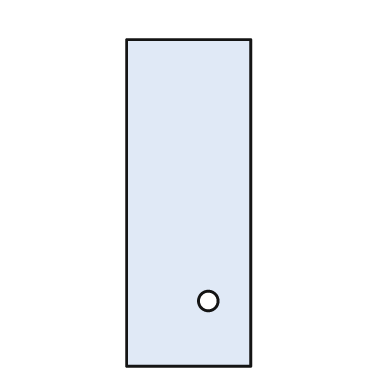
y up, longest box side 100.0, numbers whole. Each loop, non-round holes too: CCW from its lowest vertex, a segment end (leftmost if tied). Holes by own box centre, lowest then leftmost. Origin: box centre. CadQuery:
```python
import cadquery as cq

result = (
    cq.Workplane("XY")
    .moveTo(-19.0, -50.0)
    .lineTo(19.0, -50.0)
    .lineTo(19.0, 50.0)
    .lineTo(-19.0, 50.0)
    .close()
    .moveTo(6.0, -30.0)
    .circle(3.0)
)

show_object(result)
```